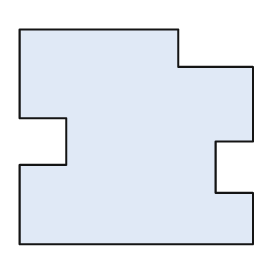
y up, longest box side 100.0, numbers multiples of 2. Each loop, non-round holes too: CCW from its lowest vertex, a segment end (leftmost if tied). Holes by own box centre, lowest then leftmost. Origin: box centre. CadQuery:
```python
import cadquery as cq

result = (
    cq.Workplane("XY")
    .moveTo(-50.0, -46.0)
    .lineTo(50.0, -46.0)
    .lineTo(50.0, -24.0)
    .lineTo(34.0, -24.0)
    .lineTo(34.0, -2.0)
    .lineTo(50.0, -2.0)
    .lineTo(50.0, 30.0)
    .lineTo(18.0, 30.0)
    .lineTo(18.0, 46.0)
    .lineTo(-50.0, 46.0)
    .lineTo(-50.0, 8.0)
    .lineTo(-30.0, 8.0)
    .lineTo(-30.0, -12.0)
    .lineTo(-50.0, -12.0)
    .close()
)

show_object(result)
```